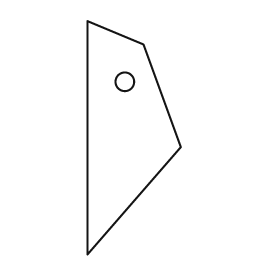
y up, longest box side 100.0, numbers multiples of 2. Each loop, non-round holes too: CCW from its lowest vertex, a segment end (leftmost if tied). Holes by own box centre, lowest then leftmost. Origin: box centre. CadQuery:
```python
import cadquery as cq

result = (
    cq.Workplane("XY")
    .moveTo(-20.0, -50.0)
    .lineTo(20.0, -4.0)
    .lineTo(4.0, 40.0)
    .lineTo(-20.0, 50.0)
    .close()
    .moveTo(-4.0, 24.0)
    .circle(4.0)
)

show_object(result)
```